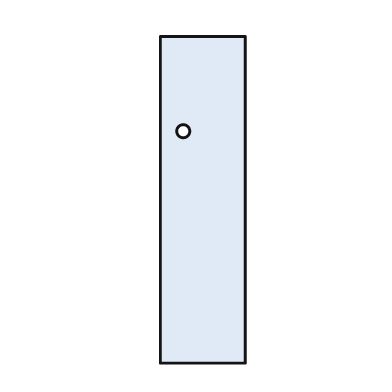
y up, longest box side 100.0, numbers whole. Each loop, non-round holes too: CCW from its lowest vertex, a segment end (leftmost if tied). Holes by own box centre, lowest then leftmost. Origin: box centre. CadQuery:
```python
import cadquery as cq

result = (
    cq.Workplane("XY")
    .moveTo(-13.0, -50.0)
    .lineTo(13.0, -50.0)
    .lineTo(13.0, 50.0)
    .lineTo(-13.0, 50.0)
    .close()
    .moveTo(-6.0, 21.0)
    .circle(2.0)
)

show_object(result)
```